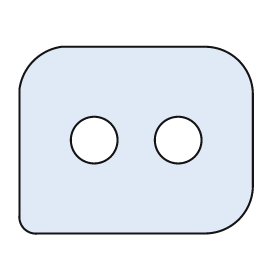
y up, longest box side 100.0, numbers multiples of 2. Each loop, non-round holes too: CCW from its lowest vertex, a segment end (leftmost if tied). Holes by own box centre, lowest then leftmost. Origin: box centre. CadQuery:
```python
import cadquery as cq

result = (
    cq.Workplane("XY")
    .moveTo(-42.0, -40.0)
    .lineTo(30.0, -40.0)
    .threePointArc((44.0, -34.0), (50.0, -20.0))
    .lineTo(50.0, 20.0)
    .threePointArc((44.0, 34.0), (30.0, 40.0))
    .lineTo(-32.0, 40.0)
    .threePointArc((-44.0, 34.0), (-50.0, 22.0))
    .lineTo(-50.0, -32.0)
    .threePointArc((-48.0, -38.0), (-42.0, -40.0))
    .close()
    .moveTo(-18.0, 0.0)
    .circle(10.0)
    .moveTo(18.0, 0.0)
    .circle(10.0)
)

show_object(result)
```